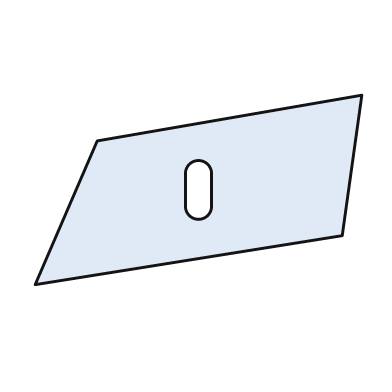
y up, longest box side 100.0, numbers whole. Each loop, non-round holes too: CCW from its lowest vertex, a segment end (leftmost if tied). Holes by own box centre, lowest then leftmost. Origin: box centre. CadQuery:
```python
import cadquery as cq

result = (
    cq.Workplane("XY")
    .moveTo(-50.0, -29.0)
    .lineTo(44.0, -14.0)
    .lineTo(50.0, 29.0)
    .lineTo(-31.0, 15.0)
    .close()
    .moveTo(-4.0, -5.0)
    .threePointArc((0.0, -9.0), (4.0, -5.0))
    .lineTo(4.0, 5.0)
    .threePointArc((0.0, 9.0), (-4.0, 5.0))
    .close()
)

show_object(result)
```